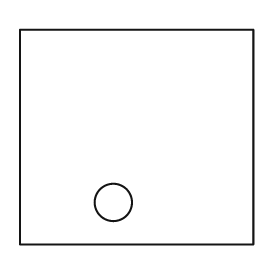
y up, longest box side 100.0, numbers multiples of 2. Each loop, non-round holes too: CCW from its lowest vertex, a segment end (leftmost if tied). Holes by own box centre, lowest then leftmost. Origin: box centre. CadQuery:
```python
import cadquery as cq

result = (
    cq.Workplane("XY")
    .moveTo(-50.0, -46.0)
    .lineTo(50.0, -46.0)
    .lineTo(50.0, 46.0)
    .lineTo(-50.0, 46.0)
    .close()
    .moveTo(-10.0, -28.0)
    .circle(8.0)
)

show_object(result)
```